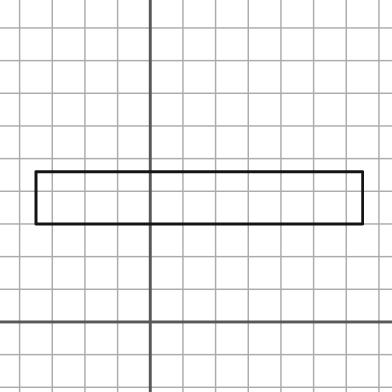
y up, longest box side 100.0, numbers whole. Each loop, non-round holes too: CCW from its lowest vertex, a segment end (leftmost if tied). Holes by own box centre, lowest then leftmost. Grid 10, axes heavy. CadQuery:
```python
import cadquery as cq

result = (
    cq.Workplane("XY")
    .moveTo(-35.0, 30.0)
    .lineTo(65.0, 30.0)
    .lineTo(65.0, 46.0)
    .lineTo(-35.0, 46.0)
    .close()
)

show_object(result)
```